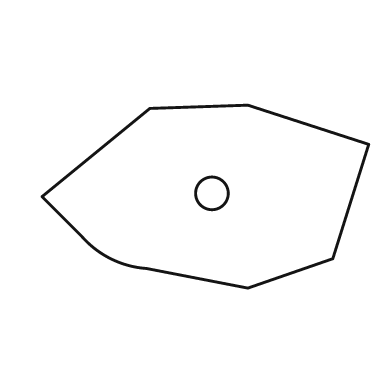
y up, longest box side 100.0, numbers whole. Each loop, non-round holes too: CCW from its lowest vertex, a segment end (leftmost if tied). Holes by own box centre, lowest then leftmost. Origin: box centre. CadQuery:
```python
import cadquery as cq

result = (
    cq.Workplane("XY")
    .moveTo(13.0, -28.0)
    .lineTo(39.0, -19.0)
    .lineTo(50.0, 16.0)
    .lineTo(13.0, 28.0)
    .lineTo(-17.0, 27.0)
    .lineTo(-50.0, 0.0)
    .lineTo(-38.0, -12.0)
    .threePointArc((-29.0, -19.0), (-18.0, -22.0))
    .close()
    .moveTo(2.0, 1.0)
    .circle(5.0)
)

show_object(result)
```